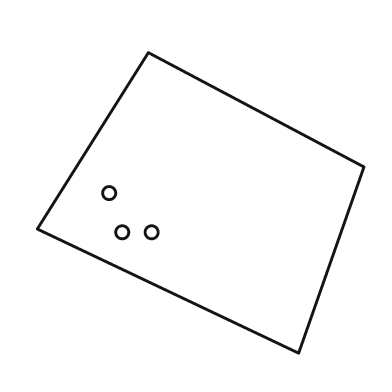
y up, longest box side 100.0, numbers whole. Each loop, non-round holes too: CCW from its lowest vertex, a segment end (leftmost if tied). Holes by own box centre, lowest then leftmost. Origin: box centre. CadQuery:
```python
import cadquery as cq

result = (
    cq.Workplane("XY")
    .moveTo(30.0, -46.0)
    .lineTo(50.0, 11.0)
    .lineTo(-16.0, 46.0)
    .lineTo(-50.0, -8.0)
    .close()
    .moveTo(-24.0, -9.0)
    .circle(2.0)
    .moveTo(-15.0, -9.0)
    .circle(2.0)
    .moveTo(-28.0, 3.0)
    .circle(2.0)
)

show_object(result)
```